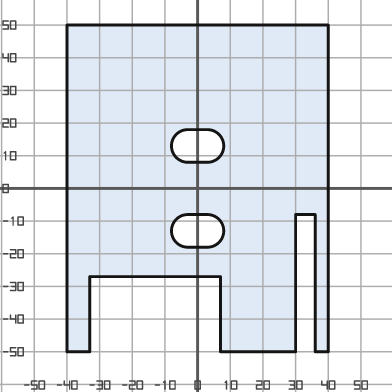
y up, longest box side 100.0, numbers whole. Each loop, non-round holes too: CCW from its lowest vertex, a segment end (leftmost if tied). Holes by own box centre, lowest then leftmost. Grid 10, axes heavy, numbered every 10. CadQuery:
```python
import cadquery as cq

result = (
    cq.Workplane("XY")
    .moveTo(-40.0, -50.0)
    .lineTo(-33.0, -50.0)
    .lineTo(-33.0, -27.0)
    .lineTo(7.0, -27.0)
    .lineTo(7.0, -50.0)
    .lineTo(30.0, -50.0)
    .lineTo(30.0, -8.0)
    .lineTo(36.0, -8.0)
    .lineTo(36.0, -50.0)
    .lineTo(40.0, -50.0)
    .lineTo(40.0, 50.0)
    .lineTo(-40.0, 50.0)
    .close()
    .moveTo(-3.0, -18.0)
    .lineTo(3.0, -18.0)
    .threePointArc((8.0, -13.0), (3.0, -8.0))
    .lineTo(-3.0, -8.0)
    .threePointArc((-8.0, -13.0), (-3.0, -18.0))
    .close()
    .moveTo(-3.0, 8.0)
    .lineTo(3.0, 8.0)
    .threePointArc((8.0, 13.0), (3.0, 18.0))
    .lineTo(-3.0, 18.0)
    .threePointArc((-8.0, 13.0), (-3.0, 8.0))
    .close()
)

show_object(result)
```